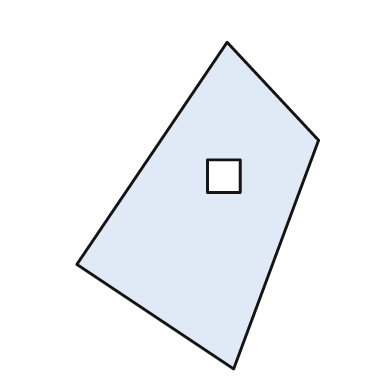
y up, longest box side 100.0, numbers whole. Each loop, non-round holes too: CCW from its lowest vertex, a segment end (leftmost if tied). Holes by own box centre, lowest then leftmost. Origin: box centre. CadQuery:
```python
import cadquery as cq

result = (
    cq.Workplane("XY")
    .moveTo(11.0, -50.0)
    .lineTo(37.0, 20.0)
    .lineTo(9.0, 50.0)
    .lineTo(-37.0, -18.0)
    .close()
    .moveTo(3.0, 4.0)
    .lineTo(13.0, 4.0)
    .lineTo(13.0, 14.0)
    .lineTo(3.0, 14.0)
    .close()
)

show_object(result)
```